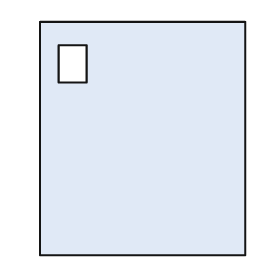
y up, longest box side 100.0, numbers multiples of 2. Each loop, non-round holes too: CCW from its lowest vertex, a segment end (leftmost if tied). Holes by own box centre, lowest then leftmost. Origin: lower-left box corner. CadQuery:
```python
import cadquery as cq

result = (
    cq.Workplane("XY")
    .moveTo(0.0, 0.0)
    .lineTo(88.0, 0.0)
    .lineTo(88.0, 100.0)
    .lineTo(0.0, 100.0)
    .close()
    .moveTo(8.0, 74.0)
    .lineTo(20.0, 74.0)
    .lineTo(20.0, 90.0)
    .lineTo(8.0, 90.0)
    .close()
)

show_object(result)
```